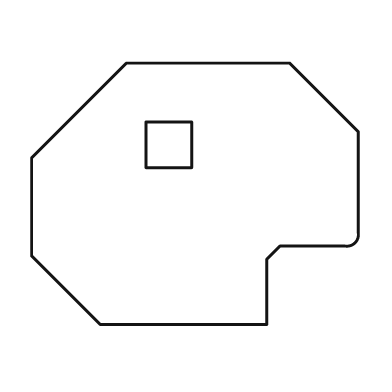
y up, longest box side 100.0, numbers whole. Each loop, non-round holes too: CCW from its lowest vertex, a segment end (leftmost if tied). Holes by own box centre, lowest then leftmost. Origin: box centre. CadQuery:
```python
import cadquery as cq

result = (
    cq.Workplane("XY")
    .moveTo(-29.0, -40.0)
    .lineTo(22.0, -40.0)
    .lineTo(22.0, -20.0)
    .lineTo(26.0, -16.0)
    .lineTo(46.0, -16.0)
    .threePointArc((49.0, -15.0), (50.0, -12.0))
    .lineTo(50.0, 19.0)
    .lineTo(29.0, 40.0)
    .lineTo(-21.0, 40.0)
    .lineTo(-50.0, 11.0)
    .lineTo(-50.0, -19.0)
    .close()
    .moveTo(-15.0, 8.0)
    .lineTo(-1.0, 8.0)
    .lineTo(-1.0, 22.0)
    .lineTo(-15.0, 22.0)
    .close()
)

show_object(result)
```